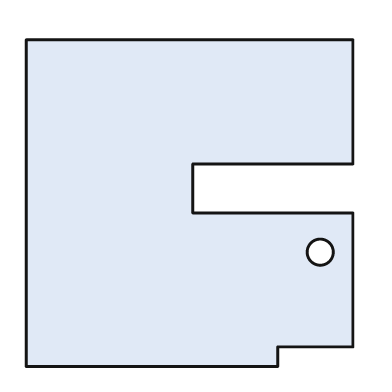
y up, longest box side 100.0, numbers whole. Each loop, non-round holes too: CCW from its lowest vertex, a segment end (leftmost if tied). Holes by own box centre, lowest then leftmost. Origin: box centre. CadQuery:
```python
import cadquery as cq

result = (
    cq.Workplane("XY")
    .moveTo(-50.0, -50.0)
    .lineTo(27.0, -50.0)
    .lineTo(27.0, -44.0)
    .lineTo(50.0, -44.0)
    .lineTo(50.0, -3.0)
    .lineTo(1.0, -3.0)
    .lineTo(1.0, 12.0)
    .lineTo(50.0, 12.0)
    .lineTo(50.0, 50.0)
    .lineTo(-50.0, 50.0)
    .close()
    .moveTo(40.0, -15.0)
    .circle(4.0)
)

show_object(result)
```